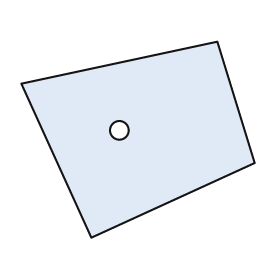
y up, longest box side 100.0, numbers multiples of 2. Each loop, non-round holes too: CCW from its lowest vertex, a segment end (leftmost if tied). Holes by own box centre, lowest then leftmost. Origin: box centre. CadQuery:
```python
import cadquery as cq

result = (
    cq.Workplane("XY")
    .moveTo(-20.0, -42.0)
    .lineTo(50.0, -10.0)
    .lineTo(34.0, 42.0)
    .lineTo(-50.0, 24.0)
    .close()
    .moveTo(-8.0, 4.0)
    .circle(4.0)
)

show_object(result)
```